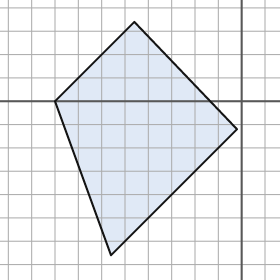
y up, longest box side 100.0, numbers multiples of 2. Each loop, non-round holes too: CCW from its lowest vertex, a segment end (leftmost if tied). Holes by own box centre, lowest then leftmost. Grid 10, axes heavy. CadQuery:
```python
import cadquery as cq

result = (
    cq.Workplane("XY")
    .moveTo(-56.0, -66.0)
    .lineTo(-2.0, -12.0)
    .lineTo(-46.0, 34.0)
    .lineTo(-80.0, 0.0)
    .close()
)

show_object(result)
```